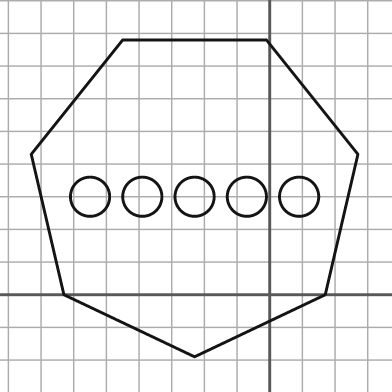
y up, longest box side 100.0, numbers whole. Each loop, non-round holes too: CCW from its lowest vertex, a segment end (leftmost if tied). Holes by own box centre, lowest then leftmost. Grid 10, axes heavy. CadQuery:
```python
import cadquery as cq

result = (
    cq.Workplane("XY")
    .moveTo(-23.0, -19.0)
    .lineTo(17.0, 0.0)
    .lineTo(27.0, 43.0)
    .lineTo(-1.0, 78.0)
    .lineTo(-45.0, 78.0)
    .lineTo(-73.0, 43.0)
    .lineTo(-63.0, 0.0)
    .close()
    .moveTo(-55.0, 30.0)
    .circle(6.0)
    .moveTo(-39.0, 30.0)
    .circle(6.0)
    .moveTo(-23.0, 30.0)
    .circle(6.0)
    .moveTo(-7.0, 30.0)
    .circle(6.0)
    .moveTo(9.0, 30.0)
    .circle(6.0)
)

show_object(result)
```